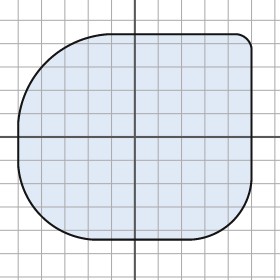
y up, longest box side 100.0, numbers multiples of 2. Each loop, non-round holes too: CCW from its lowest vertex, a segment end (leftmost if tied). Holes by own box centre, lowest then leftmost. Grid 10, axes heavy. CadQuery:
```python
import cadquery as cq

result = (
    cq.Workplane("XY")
    .moveTo(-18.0, -44.0)
    .lineTo(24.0, -44.0)
    .threePointArc((42.0, -36.0), (50.0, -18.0))
    .lineTo(50.0, 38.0)
    .threePointArc((48.0, 42.0), (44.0, 44.0))
    .lineTo(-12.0, 44.0)
    .threePointArc((-38.0, 32.0), (-50.0, 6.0))
    .lineTo(-50.0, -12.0)
    .threePointArc((-40.0, -34.0), (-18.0, -44.0))
    .close()
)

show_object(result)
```